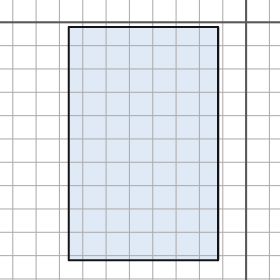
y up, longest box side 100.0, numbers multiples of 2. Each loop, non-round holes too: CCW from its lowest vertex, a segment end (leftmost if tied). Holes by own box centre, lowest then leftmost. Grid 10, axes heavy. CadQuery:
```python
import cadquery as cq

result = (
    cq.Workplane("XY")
    .moveTo(-76.0, -102.0)
    .lineTo(-12.0, -102.0)
    .lineTo(-12.0, -2.0)
    .lineTo(-76.0, -2.0)
    .close()
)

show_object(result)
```